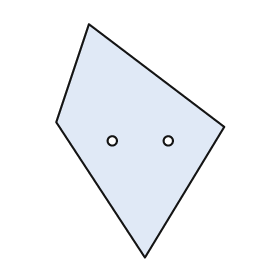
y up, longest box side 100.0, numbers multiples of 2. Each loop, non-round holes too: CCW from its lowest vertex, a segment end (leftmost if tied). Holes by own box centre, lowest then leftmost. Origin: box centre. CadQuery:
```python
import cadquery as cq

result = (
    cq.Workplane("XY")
    .moveTo(2.0, -50.0)
    .lineTo(36.0, 6.0)
    .lineTo(-22.0, 50.0)
    .lineTo(-36.0, 8.0)
    .close()
    .moveTo(-12.0, 0.0)
    .circle(2.0)
    .moveTo(12.0, 0.0)
    .circle(2.0)
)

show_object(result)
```